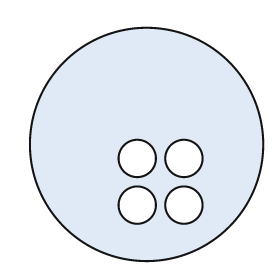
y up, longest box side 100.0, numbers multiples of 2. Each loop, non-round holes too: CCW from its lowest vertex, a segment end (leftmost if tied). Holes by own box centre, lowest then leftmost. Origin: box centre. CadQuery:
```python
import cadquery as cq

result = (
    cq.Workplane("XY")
    .moveTo(0.0, 0.0)
    .circle(50.0)
    .moveTo(-4.0, -26.0)
    .circle(8.0)
    .moveTo(16.0, -26.0)
    .circle(8.0)
    .moveTo(-4.0, -6.0)
    .circle(8.0)
    .moveTo(16.0, -6.0)
    .circle(8.0)
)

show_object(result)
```